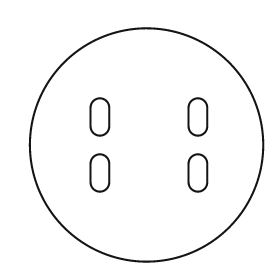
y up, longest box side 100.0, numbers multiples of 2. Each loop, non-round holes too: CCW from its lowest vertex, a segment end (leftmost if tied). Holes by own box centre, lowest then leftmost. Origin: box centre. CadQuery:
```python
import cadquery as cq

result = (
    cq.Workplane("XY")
    .moveTo(0.0, 0.0)
    .circle(50.0)
    .moveTo(-24.0, -16.0)
    .threePointArc((-20.0, -20.0), (-16.0, -16.0))
    .lineTo(-16.0, -8.0)
    .threePointArc((-20.0, -4.0), (-24.0, -8.0))
    .close()
    .moveTo(18.0, -16.0)
    .threePointArc((22.0, -20.0), (26.0, -16.0))
    .lineTo(26.0, -8.0)
    .threePointArc((22.0, -4.0), (18.0, -8.0))
    .close()
    .moveTo(-24.0, 8.0)
    .threePointArc((-20.0, 4.0), (-16.0, 8.0))
    .lineTo(-16.0, 16.0)
    .threePointArc((-20.0, 20.0), (-24.0, 16.0))
    .close()
    .moveTo(18.0, 8.0)
    .threePointArc((22.0, 4.0), (26.0, 8.0))
    .lineTo(26.0, 16.0)
    .threePointArc((22.0, 20.0), (18.0, 16.0))
    .close()
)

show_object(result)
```